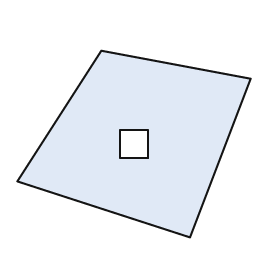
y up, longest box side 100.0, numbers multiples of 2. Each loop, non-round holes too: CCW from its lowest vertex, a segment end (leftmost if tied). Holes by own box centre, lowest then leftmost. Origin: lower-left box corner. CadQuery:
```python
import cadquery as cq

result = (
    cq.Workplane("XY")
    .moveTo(74.0, 0.0)
    .lineTo(100.0, 68.0)
    .lineTo(36.0, 80.0)
    .lineTo(0.0, 24.0)
    .close()
    .moveTo(44.0, 34.0)
    .lineTo(56.0, 34.0)
    .lineTo(56.0, 46.0)
    .lineTo(44.0, 46.0)
    .close()
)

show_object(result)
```